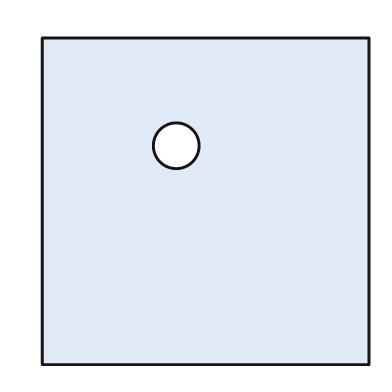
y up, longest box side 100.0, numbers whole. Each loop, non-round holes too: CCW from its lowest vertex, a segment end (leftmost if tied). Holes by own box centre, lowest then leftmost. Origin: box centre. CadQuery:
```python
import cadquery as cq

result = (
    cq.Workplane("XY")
    .moveTo(-50.0, -50.0)
    .lineTo(50.0, -50.0)
    .lineTo(50.0, 50.0)
    .lineTo(-50.0, 50.0)
    .close()
    .moveTo(-9.0, 17.0)
    .circle(7.0)
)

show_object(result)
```